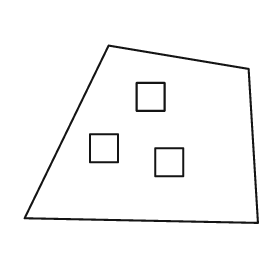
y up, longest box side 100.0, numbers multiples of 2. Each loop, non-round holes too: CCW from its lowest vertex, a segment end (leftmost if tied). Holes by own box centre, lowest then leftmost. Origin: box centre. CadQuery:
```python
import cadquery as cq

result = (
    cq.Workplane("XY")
    .moveTo(50.0, -38.0)
    .lineTo(46.0, 28.0)
    .lineTo(-14.0, 38.0)
    .lineTo(-50.0, -36.0)
    .close()
    .moveTo(6.0, -18.0)
    .lineTo(18.0, -18.0)
    .lineTo(18.0, -6.0)
    .lineTo(6.0, -6.0)
    .close()
    .moveTo(-22.0, -12.0)
    .lineTo(-10.0, -12.0)
    .lineTo(-10.0, 0.0)
    .lineTo(-22.0, 0.0)
    .close()
    .moveTo(-2.0, 10.0)
    .lineTo(10.0, 10.0)
    .lineTo(10.0, 22.0)
    .lineTo(-2.0, 22.0)
    .close()
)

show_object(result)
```